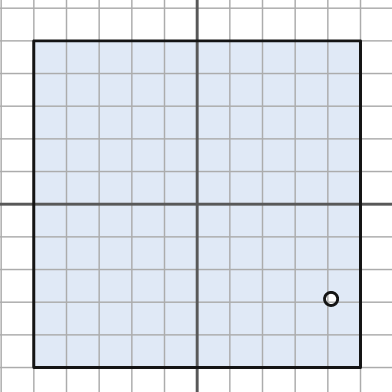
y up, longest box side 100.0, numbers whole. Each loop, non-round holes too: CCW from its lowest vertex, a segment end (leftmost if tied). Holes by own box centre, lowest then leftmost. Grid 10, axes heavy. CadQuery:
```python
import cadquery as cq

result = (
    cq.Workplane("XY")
    .moveTo(-50.0, -50.0)
    .lineTo(50.0, -50.0)
    .lineTo(50.0, 50.0)
    .lineTo(-50.0, 50.0)
    .close()
    .moveTo(41.0, -29.0)
    .circle(2.0)
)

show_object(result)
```